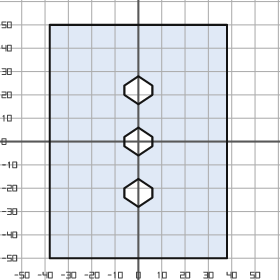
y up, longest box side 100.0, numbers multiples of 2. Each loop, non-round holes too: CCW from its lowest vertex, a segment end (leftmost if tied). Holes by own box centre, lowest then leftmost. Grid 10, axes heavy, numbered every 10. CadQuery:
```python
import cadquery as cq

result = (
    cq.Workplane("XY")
    .moveTo(-38.0, -50.0)
    .lineTo(38.0, -50.0)
    .lineTo(38.0, 50.0)
    .lineTo(-38.0, 50.0)
    .close()
    .moveTo(0.0, -28.0)
    .lineTo(6.0, -24.0)
    .lineTo(6.0, -20.0)
    .lineTo(0.0, -16.0)
    .lineTo(-6.0, -20.0)
    .lineTo(-6.0, -24.0)
    .close()
    .moveTo(0.0, -6.0)
    .lineTo(6.0, -2.0)
    .lineTo(6.0, 2.0)
    .lineTo(0.0, 6.0)
    .lineTo(-6.0, 2.0)
    .lineTo(-6.0, -2.0)
    .close()
    .moveTo(0.0, 16.0)
    .lineTo(6.0, 20.0)
    .lineTo(6.0, 24.0)
    .lineTo(0.0, 28.0)
    .lineTo(-6.0, 24.0)
    .lineTo(-6.0, 20.0)
    .close()
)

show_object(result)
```